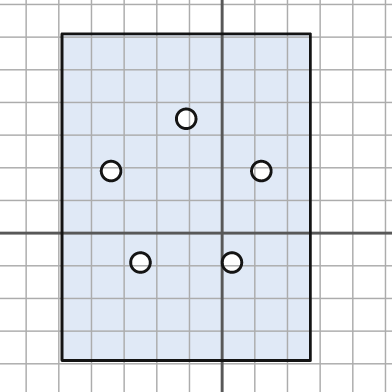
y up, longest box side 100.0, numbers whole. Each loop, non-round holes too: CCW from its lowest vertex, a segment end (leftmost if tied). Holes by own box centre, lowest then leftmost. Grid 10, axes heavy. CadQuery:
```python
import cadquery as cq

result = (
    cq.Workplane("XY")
    .moveTo(-49.0, -39.0)
    .lineTo(27.0, -39.0)
    .lineTo(27.0, 61.0)
    .lineTo(-49.0, 61.0)
    .close()
    .moveTo(-25.0, -9.0)
    .circle(3.0)
    .moveTo(3.0, -9.0)
    .circle(3.0)
    .moveTo(-34.0, 19.0)
    .circle(3.0)
    .moveTo(12.0, 19.0)
    .circle(3.0)
    .moveTo(-11.0, 35.0)
    .circle(3.0)
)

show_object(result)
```